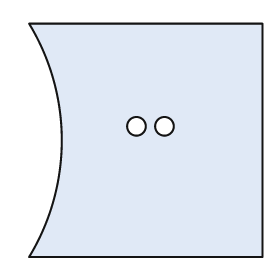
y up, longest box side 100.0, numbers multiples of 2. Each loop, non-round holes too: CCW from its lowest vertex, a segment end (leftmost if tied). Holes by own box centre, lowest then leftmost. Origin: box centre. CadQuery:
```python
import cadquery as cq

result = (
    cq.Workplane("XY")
    .moveTo(-50.0, -50.0)
    .lineTo(50.0, -50.0)
    .lineTo(50.0, 50.0)
    .lineTo(-50.0, 50.0)
    .threePointArc((-36.0, 0.0), (-50.0, -50.0))
    .close()
    .moveTo(-4.0, 6.0)
    .circle(4.0)
    .moveTo(8.0, 6.0)
    .circle(4.0)
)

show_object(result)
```